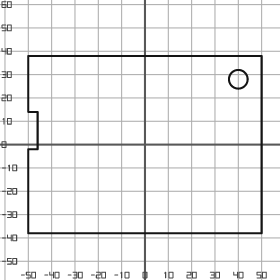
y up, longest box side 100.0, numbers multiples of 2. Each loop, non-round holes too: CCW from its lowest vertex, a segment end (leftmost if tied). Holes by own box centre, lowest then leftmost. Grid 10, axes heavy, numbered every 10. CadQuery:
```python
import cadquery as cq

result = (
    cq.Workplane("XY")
    .moveTo(-50.0, -38.0)
    .lineTo(50.0, -38.0)
    .lineTo(50.0, 38.0)
    .lineTo(-50.0, 38.0)
    .lineTo(-50.0, 14.0)
    .lineTo(-46.0, 14.0)
    .lineTo(-46.0, -2.0)
    .lineTo(-50.0, -2.0)
    .close()
    .moveTo(40.0, 28.0)
    .circle(4.0)
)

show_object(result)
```